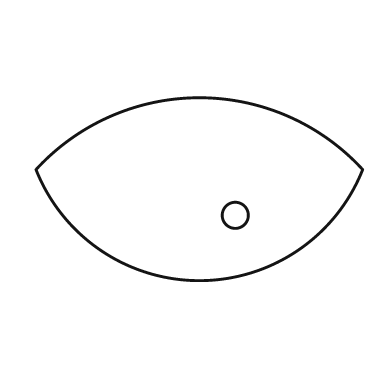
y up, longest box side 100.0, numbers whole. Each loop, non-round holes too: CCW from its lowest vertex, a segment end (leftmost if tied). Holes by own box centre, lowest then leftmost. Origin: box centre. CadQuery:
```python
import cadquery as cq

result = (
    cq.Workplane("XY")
    .moveTo(-50.0, 6.0)
    .threePointArc((0.0, -28.0), (50.0, 6.0))
    .threePointArc((0.0, 28.0), (-50.0, 6.0))
    .close()
    .moveTo(11.0, -8.0)
    .circle(4.0)
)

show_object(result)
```